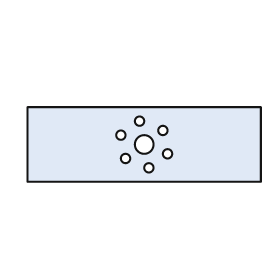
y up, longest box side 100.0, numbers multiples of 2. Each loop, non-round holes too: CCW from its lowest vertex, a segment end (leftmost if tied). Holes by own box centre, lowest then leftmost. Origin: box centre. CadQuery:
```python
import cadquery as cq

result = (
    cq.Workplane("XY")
    .moveTo(-50.0, -16.0)
    .lineTo(50.0, -16.0)
    .lineTo(50.0, 16.0)
    .lineTo(-50.0, 16.0)
    .close()
    .moveTo(2.0, -10.0)
    .circle(2.0)
    .moveTo(-8.0, -6.0)
    .circle(2.0)
    .moveTo(10.0, -4.0)
    .circle(2.0)
    .moveTo(0.0, 0.0)
    .circle(4.0)
    .moveTo(-10.0, 4.0)
    .circle(2.0)
    .moveTo(8.0, 6.0)
    .circle(2.0)
    .moveTo(-2.0, 10.0)
    .circle(2.0)
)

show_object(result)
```